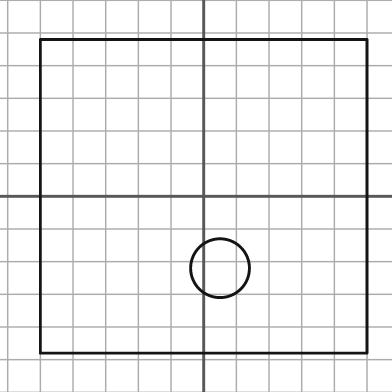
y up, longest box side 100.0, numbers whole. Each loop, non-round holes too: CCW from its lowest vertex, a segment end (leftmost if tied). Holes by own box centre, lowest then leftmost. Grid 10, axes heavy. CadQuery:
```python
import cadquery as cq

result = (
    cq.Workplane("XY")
    .moveTo(-50.0, -48.0)
    .lineTo(50.0, -48.0)
    .lineTo(50.0, 48.0)
    .lineTo(-50.0, 48.0)
    .close()
    .moveTo(5.0, -22.0)
    .circle(9.0)
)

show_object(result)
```